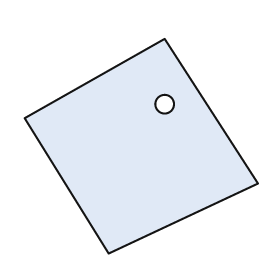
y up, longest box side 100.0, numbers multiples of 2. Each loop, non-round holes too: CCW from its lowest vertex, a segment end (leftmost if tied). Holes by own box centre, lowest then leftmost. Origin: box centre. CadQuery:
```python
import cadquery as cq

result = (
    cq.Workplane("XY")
    .moveTo(-14.0, -46.0)
    .lineTo(50.0, -16.0)
    .lineTo(10.0, 46.0)
    .lineTo(-50.0, 12.0)
    .close()
    .moveTo(10.0, 18.0)
    .circle(4.0)
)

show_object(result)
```